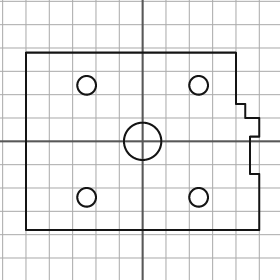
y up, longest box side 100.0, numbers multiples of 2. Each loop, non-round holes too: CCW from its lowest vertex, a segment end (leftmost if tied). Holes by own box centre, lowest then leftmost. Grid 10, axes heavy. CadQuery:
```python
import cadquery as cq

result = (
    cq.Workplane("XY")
    .moveTo(-50.0, -38.0)
    .lineTo(50.0, -38.0)
    .lineTo(50.0, -14.0)
    .lineTo(46.0, -14.0)
    .lineTo(46.0, 2.0)
    .lineTo(50.0, 2.0)
    .lineTo(50.0, 10.0)
    .lineTo(44.0, 10.0)
    .lineTo(44.0, 16.0)
    .lineTo(40.0, 16.0)
    .lineTo(40.0, 38.0)
    .lineTo(-50.0, 38.0)
    .close()
    .moveTo(-24.0, -24.0)
    .circle(4.0)
    .moveTo(24.0, -24.0)
    .circle(4.0)
    .moveTo(0.0, 0.0)
    .circle(8.0)
    .moveTo(-24.0, 24.0)
    .circle(4.0)
    .moveTo(24.0, 24.0)
    .circle(4.0)
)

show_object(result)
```